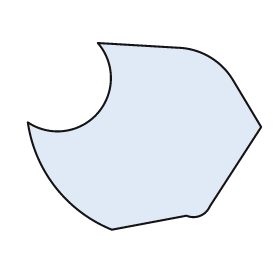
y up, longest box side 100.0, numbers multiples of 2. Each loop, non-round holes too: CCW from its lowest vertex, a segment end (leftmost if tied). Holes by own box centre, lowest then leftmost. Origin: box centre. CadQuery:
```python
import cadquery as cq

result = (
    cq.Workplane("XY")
    .moveTo(-14.0, -40.0)
    .lineTo(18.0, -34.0)
    .threePointArc((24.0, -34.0), (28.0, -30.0))
    .lineTo(50.0, 4.0)
    .lineTo(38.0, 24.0)
    .threePointArc((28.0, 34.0), (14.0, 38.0))
    .lineTo(-20.0, 40.0)
    .threePointArc((-20.0, 10.0), (-50.0, 6.0))
    .threePointArc((-38.0, -22.0), (-14.0, -40.0))
    .close()
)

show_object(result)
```